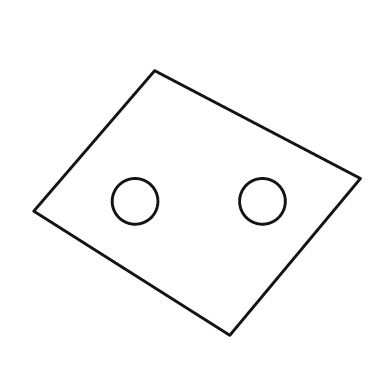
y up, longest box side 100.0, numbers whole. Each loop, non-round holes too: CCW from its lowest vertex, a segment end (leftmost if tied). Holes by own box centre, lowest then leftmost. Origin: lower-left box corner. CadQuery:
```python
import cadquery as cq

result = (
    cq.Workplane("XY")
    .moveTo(60.0, 0.0)
    .lineTo(100.0, 48.0)
    .lineTo(37.0, 81.0)
    .lineTo(0.0, 38.0)
    .close()
    .moveTo(31.0, 41.0)
    .circle(7.0)
    .moveTo(70.0, 41.0)
    .circle(7.0)
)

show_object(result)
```